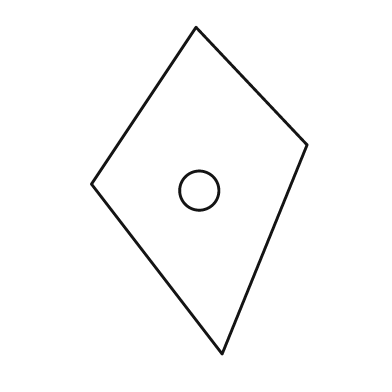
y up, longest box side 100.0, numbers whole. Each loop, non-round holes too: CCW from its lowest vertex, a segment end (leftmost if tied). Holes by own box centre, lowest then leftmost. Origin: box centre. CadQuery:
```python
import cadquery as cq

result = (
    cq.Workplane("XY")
    .moveTo(7.0, -50.0)
    .lineTo(33.0, 14.0)
    .lineTo(-1.0, 50.0)
    .lineTo(-33.0, 2.0)
    .close()
    .moveTo(0.0, 0.0)
    .circle(6.0)
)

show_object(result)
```